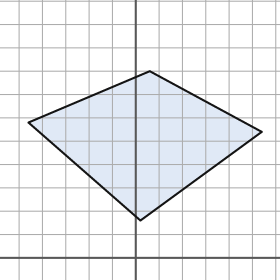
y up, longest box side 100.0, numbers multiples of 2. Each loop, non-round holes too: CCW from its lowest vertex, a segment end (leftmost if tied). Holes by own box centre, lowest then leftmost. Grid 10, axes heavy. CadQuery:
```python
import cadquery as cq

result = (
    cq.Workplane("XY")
    .moveTo(2.0, 16.0)
    .lineTo(54.0, 54.0)
    .lineTo(6.0, 80.0)
    .lineTo(-46.0, 58.0)
    .close()
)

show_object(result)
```